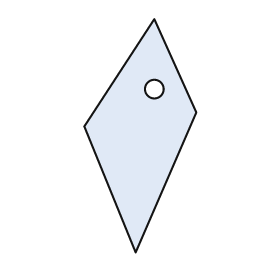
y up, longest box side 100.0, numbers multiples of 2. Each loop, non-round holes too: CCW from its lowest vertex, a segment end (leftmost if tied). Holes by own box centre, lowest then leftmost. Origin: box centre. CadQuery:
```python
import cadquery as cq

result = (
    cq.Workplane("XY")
    .moveTo(-2.0, -50.0)
    .lineTo(24.0, 10.0)
    .lineTo(6.0, 50.0)
    .lineTo(-24.0, 4.0)
    .close()
    .moveTo(6.0, 20.0)
    .circle(4.0)
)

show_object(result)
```